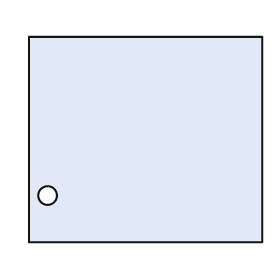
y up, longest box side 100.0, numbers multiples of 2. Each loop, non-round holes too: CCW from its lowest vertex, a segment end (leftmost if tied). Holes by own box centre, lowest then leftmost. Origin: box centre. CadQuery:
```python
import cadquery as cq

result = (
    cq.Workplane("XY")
    .moveTo(-50.0, -44.0)
    .lineTo(50.0, -44.0)
    .lineTo(50.0, 44.0)
    .lineTo(-50.0, 44.0)
    .close()
    .moveTo(-42.0, -24.0)
    .circle(4.0)
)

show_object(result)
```